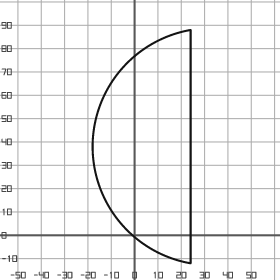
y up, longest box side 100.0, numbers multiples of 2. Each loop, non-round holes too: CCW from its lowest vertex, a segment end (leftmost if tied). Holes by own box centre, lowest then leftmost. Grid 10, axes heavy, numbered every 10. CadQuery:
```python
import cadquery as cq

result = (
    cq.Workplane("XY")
    .moveTo(24.0, -12.0)
    .lineTo(24.0, 88.0)
    .threePointArc((-18.0, 38.0), (24.0, -12.0))
    .close()
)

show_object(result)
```